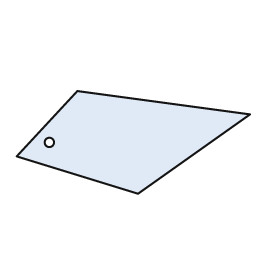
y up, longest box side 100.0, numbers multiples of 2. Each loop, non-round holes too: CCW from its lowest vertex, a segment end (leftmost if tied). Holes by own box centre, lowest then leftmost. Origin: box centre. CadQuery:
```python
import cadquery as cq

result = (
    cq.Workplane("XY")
    .moveTo(2.0, -22.0)
    .lineTo(50.0, 12.0)
    .lineTo(-24.0, 22.0)
    .lineTo(-50.0, -6.0)
    .close()
    .moveTo(-36.0, 0.0)
    .circle(2.0)
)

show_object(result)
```